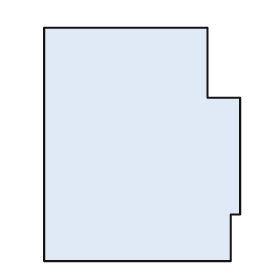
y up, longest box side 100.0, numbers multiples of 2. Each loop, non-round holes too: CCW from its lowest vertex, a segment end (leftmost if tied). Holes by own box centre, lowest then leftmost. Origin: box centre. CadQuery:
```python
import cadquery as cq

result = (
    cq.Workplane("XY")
    .moveTo(-42.0, -50.0)
    .lineTo(38.0, -50.0)
    .lineTo(38.0, -30.0)
    .lineTo(42.0, -30.0)
    .lineTo(42.0, 20.0)
    .lineTo(28.0, 20.0)
    .lineTo(28.0, 50.0)
    .lineTo(-42.0, 50.0)
    .close()
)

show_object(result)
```